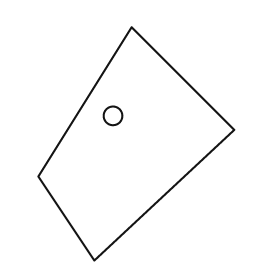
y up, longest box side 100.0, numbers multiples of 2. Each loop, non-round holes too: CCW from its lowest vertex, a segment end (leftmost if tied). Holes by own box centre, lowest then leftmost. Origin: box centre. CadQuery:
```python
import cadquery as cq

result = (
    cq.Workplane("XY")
    .moveTo(-18.0, -50.0)
    .lineTo(42.0, 6.0)
    .lineTo(-2.0, 50.0)
    .lineTo(-42.0, -14.0)
    .close()
    .moveTo(-10.0, 12.0)
    .circle(4.0)
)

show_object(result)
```